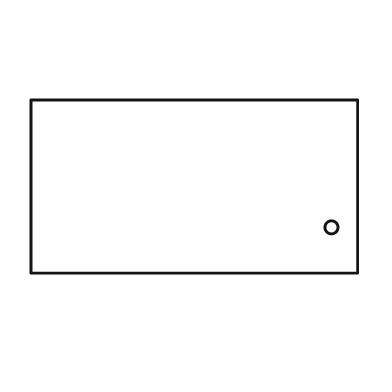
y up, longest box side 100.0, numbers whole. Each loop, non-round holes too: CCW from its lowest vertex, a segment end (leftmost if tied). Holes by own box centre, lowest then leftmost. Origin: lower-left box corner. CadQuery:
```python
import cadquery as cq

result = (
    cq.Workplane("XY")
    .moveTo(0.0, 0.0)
    .lineTo(100.0, 0.0)
    .lineTo(100.0, 53.0)
    .lineTo(0.0, 53.0)
    .close()
    .moveTo(92.0, 14.0)
    .circle(2.0)
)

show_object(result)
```